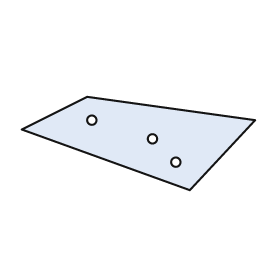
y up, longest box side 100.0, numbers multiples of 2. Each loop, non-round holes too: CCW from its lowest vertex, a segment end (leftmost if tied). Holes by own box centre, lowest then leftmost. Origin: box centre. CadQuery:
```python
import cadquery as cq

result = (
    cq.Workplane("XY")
    .moveTo(22.0, -20.0)
    .lineTo(50.0, 10.0)
    .lineTo(-22.0, 20.0)
    .lineTo(-50.0, 6.0)
    .close()
    .moveTo(16.0, -8.0)
    .circle(2.0)
    .moveTo(6.0, 2.0)
    .circle(2.0)
    .moveTo(-20.0, 10.0)
    .circle(2.0)
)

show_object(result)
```